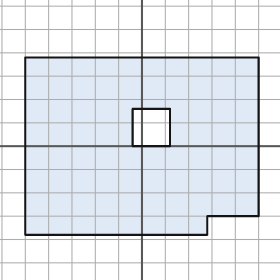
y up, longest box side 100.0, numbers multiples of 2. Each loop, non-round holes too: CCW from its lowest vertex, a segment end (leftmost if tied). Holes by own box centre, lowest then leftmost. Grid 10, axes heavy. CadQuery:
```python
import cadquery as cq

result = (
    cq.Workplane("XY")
    .moveTo(-50.0, -38.0)
    .lineTo(28.0, -38.0)
    .lineTo(28.0, -30.0)
    .lineTo(50.0, -30.0)
    .lineTo(50.0, 38.0)
    .lineTo(-50.0, 38.0)
    .close()
    .moveTo(-4.0, 0.0)
    .lineTo(12.0, 0.0)
    .lineTo(12.0, 16.0)
    .lineTo(-4.0, 16.0)
    .close()
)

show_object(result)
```